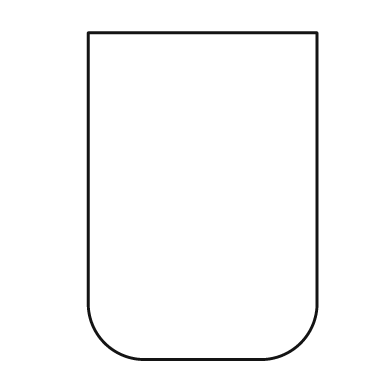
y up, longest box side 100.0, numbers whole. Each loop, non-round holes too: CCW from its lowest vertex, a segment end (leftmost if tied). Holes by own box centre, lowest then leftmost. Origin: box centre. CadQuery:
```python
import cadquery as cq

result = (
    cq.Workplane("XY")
    .moveTo(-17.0, -50.0)
    .lineTo(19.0, -50.0)
    .threePointArc((30.0, -45.0), (35.0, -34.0))
    .lineTo(35.0, 50.0)
    .lineTo(-35.0, 50.0)
    .lineTo(-35.0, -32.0)
    .threePointArc((-30.0, -45.0), (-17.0, -50.0))
    .close()
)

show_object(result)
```